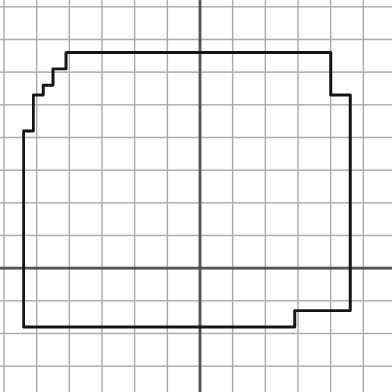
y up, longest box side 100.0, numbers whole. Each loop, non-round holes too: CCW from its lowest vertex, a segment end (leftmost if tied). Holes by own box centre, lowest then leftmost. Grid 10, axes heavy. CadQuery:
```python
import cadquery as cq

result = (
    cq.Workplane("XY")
    .moveTo(-54.0, -18.0)
    .lineTo(29.0, -18.0)
    .lineTo(29.0, -13.0)
    .lineTo(46.0, -13.0)
    .lineTo(46.0, 53.0)
    .lineTo(40.0, 53.0)
    .lineTo(40.0, 66.0)
    .lineTo(-41.0, 66.0)
    .lineTo(-41.0, 61.0)
    .lineTo(-45.0, 61.0)
    .lineTo(-45.0, 56.0)
    .lineTo(-48.0, 56.0)
    .lineTo(-48.0, 53.0)
    .lineTo(-51.0, 53.0)
    .lineTo(-51.0, 42.0)
    .lineTo(-54.0, 42.0)
    .close()
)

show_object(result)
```